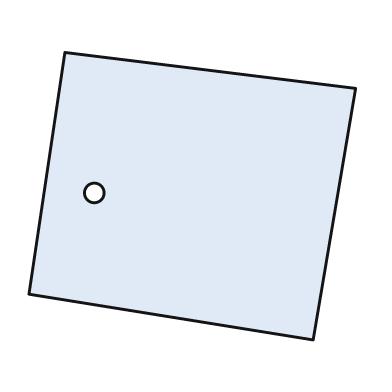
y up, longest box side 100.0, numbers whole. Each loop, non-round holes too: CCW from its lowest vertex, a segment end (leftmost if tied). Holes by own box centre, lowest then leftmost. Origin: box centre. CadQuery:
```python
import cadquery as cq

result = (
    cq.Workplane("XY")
    .moveTo(37.0, -44.0)
    .lineTo(50.0, 33.0)
    .lineTo(-39.0, 44.0)
    .lineTo(-50.0, -30.0)
    .close()
    .moveTo(-30.0, 1.0)
    .circle(3.0)
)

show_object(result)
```